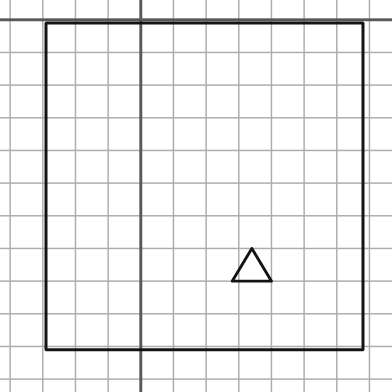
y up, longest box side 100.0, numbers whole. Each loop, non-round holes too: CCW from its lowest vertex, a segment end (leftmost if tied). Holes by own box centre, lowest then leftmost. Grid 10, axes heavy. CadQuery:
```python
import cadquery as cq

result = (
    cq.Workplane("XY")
    .moveTo(-29.0, -101.0)
    .lineTo(68.0, -101.0)
    .lineTo(68.0, -1.0)
    .lineTo(-29.0, -1.0)
    .close()
    .moveTo(28.0, -80.0)
    .lineTo(40.0, -80.0)
    .lineTo(34.0, -70.0)
    .close()
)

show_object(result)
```